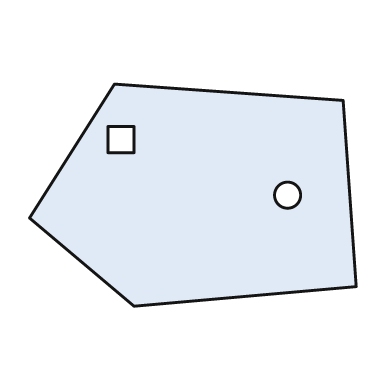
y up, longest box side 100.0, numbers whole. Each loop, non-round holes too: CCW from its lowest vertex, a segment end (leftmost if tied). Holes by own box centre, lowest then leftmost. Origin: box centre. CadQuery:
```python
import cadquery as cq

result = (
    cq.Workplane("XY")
    .moveTo(-18.0, -34.0)
    .lineTo(50.0, -28.0)
    .lineTo(46.0, 29.0)
    .lineTo(-24.0, 34.0)
    .lineTo(-50.0, -7.0)
    .close()
    .moveTo(29.0, 0.0)
    .circle(4.0)
    .moveTo(-26.0, 13.0)
    .lineTo(-18.0, 13.0)
    .lineTo(-18.0, 21.0)
    .lineTo(-26.0, 21.0)
    .close()
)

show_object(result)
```